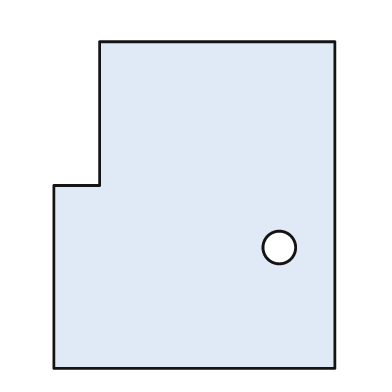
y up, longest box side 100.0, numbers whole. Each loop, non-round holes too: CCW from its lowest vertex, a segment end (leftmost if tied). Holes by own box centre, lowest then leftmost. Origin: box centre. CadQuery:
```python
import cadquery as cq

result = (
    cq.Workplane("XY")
    .moveTo(-43.0, -50.0)
    .lineTo(43.0, -50.0)
    .lineTo(43.0, 50.0)
    .lineTo(-29.0, 50.0)
    .lineTo(-29.0, 6.0)
    .lineTo(-43.0, 6.0)
    .close()
    .moveTo(26.0, -13.0)
    .circle(5.0)
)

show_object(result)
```